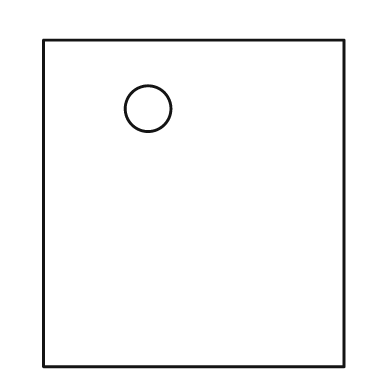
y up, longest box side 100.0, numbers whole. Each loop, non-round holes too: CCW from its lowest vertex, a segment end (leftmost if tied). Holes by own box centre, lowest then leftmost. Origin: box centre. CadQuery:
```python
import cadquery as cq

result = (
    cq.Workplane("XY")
    .moveTo(-46.0, -50.0)
    .lineTo(46.0, -50.0)
    .lineTo(46.0, 50.0)
    .lineTo(-46.0, 50.0)
    .close()
    .moveTo(-14.0, 29.0)
    .circle(7.0)
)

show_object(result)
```